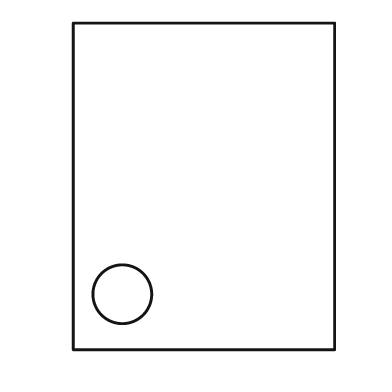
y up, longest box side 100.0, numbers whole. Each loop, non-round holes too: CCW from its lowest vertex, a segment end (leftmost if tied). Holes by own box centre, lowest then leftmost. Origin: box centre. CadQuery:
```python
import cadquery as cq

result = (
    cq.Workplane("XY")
    .moveTo(-40.0, -50.0)
    .lineTo(40.0, -50.0)
    .lineTo(40.0, 50.0)
    .lineTo(-40.0, 50.0)
    .close()
    .moveTo(-25.0, -33.0)
    .circle(9.0)
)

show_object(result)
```